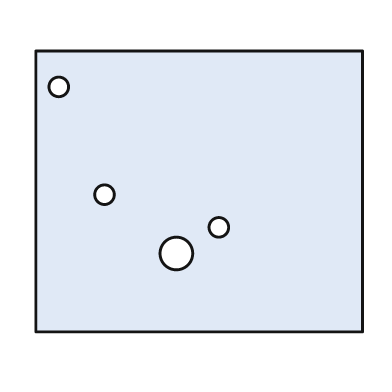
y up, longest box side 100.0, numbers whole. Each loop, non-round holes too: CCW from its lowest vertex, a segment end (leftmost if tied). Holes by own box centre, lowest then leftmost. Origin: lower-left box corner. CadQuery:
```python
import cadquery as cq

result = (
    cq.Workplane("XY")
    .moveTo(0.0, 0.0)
    .lineTo(100.0, 0.0)
    .lineTo(100.0, 86.0)
    .lineTo(0.0, 86.0)
    .close()
    .moveTo(43.0, 24.0)
    .circle(5.0)
    .moveTo(56.0, 32.0)
    .circle(3.0)
    .moveTo(21.0, 42.0)
    .circle(3.0)
    .moveTo(7.0, 75.0)
    .circle(3.0)
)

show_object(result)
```